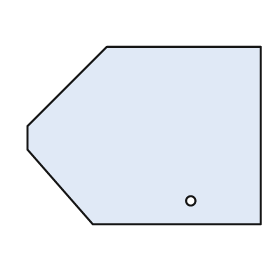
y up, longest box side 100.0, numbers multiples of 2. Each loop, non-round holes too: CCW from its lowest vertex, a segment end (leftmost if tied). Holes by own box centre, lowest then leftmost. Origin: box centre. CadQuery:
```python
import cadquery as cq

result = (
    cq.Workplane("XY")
    .moveTo(-22.0, -38.0)
    .lineTo(50.0, -38.0)
    .lineTo(50.0, 38.0)
    .lineTo(-16.0, 38.0)
    .lineTo(-50.0, 4.0)
    .lineTo(-50.0, -6.0)
    .close()
    .moveTo(20.0, -28.0)
    .circle(2.0)
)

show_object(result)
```